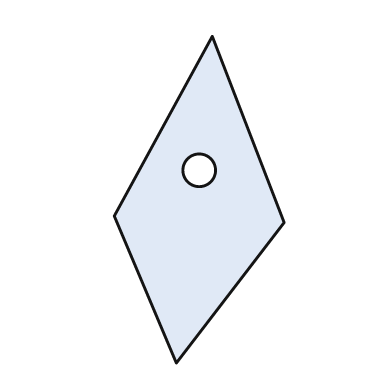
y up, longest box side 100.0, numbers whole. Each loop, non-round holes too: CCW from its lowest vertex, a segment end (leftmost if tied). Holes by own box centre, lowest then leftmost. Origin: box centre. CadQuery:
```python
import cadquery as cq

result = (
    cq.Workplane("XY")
    .moveTo(-7.0, -50.0)
    .lineTo(26.0, -7.0)
    .lineTo(4.0, 50.0)
    .lineTo(-26.0, -5.0)
    .close()
    .moveTo(0.0, 9.0)
    .circle(5.0)
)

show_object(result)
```